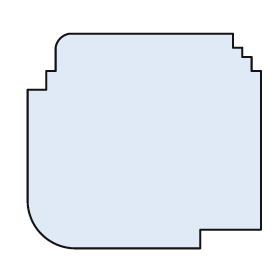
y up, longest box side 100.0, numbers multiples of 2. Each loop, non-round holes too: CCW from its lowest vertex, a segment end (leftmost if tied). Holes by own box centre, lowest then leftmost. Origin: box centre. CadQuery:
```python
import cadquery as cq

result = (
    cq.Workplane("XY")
    .moveTo(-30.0, -46.0)
    .lineTo(24.0, -46.0)
    .lineTo(24.0, -38.0)
    .lineTo(50.0, -38.0)
    .lineTo(50.0, 30.0)
    .lineTo(46.0, 30.0)
    .lineTo(46.0, 36.0)
    .lineTo(42.0, 36.0)
    .lineTo(42.0, 40.0)
    .lineTo(38.0, 40.0)
    .lineTo(38.0, 46.0)
    .lineTo(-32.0, 46.0)
    .threePointArc((-36.0, 44.0), (-38.0, 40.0))
    .lineTo(-38.0, 30.0)
    .lineTo(-42.0, 30.0)
    .lineTo(-42.0, 22.0)
    .lineTo(-50.0, 22.0)
    .lineTo(-50.0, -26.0)
    .threePointArc((-44.0, -40.0), (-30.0, -46.0))
    .close()
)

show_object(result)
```